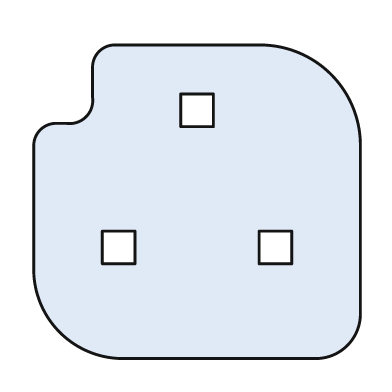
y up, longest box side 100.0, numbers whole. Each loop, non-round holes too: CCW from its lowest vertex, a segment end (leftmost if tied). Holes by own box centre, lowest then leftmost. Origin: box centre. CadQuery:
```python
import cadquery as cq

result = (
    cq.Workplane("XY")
    .moveTo(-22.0, -48.0)
    .lineTo(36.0, -48.0)
    .threePointArc((46.0, -44.0), (50.0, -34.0))
    .lineTo(50.0, 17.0)
    .threePointArc((41.0, 39.0), (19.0, 48.0))
    .lineTo(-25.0, 48.0)
    .threePointArc((-30.0, 46.0), (-32.0, 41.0))
    .lineTo(-32.0, 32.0)
    .threePointArc((-34.0, 26.0), (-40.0, 24.0))
    .lineTo(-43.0, 24.0)
    .threePointArc((-48.0, 22.0), (-50.0, 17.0))
    .lineTo(-50.0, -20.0)
    .threePointArc((-42.0, -40.0), (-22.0, -48.0))
    .close()
    .moveTo(-29.0, -19.0)
    .lineTo(-19.0, -19.0)
    .lineTo(-19.0, -9.0)
    .lineTo(-29.0, -9.0)
    .close()
    .moveTo(19.0, -19.0)
    .lineTo(29.0, -19.0)
    .lineTo(29.0, -9.0)
    .lineTo(19.0, -9.0)
    .close()
    .moveTo(-5.0, 23.0)
    .lineTo(5.0, 23.0)
    .lineTo(5.0, 33.0)
    .lineTo(-5.0, 33.0)
    .close()
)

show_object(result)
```